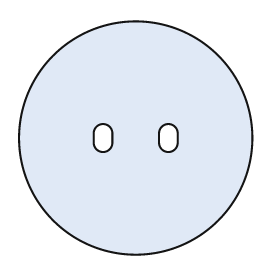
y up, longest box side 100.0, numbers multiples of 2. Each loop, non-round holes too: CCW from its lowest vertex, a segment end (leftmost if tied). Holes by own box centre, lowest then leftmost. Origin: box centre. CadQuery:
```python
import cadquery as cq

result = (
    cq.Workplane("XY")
    .moveTo(0.0, 0.0)
    .circle(50.0)
    .moveTo(-18.0, -2.0)
    .threePointArc((-14.0, -6.0), (-10.0, -2.0))
    .lineTo(-10.0, 2.0)
    .threePointArc((-14.0, 6.0), (-18.0, 2.0))
    .close()
    .moveTo(10.0, -2.0)
    .threePointArc((14.0, -6.0), (18.0, -2.0))
    .lineTo(18.0, 2.0)
    .threePointArc((14.0, 6.0), (10.0, 2.0))
    .close()
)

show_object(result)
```